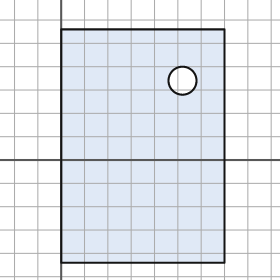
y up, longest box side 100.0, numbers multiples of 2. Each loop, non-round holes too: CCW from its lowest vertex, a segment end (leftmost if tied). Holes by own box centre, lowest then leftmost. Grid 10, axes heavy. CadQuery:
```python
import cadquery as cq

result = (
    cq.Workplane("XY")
    .moveTo(0.0, -44.0)
    .lineTo(70.0, -44.0)
    .lineTo(70.0, 56.0)
    .lineTo(0.0, 56.0)
    .close()
    .moveTo(52.0, 34.0)
    .circle(6.0)
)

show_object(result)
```